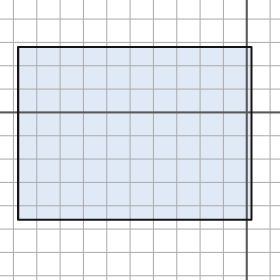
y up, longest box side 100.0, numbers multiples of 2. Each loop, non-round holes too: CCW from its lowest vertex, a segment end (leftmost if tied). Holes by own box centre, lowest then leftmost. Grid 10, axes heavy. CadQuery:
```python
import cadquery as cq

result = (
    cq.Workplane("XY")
    .moveTo(-98.0, -46.0)
    .lineTo(2.0, -46.0)
    .lineTo(2.0, 28.0)
    .lineTo(-98.0, 28.0)
    .close()
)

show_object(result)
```